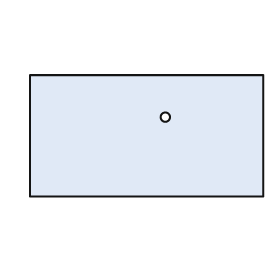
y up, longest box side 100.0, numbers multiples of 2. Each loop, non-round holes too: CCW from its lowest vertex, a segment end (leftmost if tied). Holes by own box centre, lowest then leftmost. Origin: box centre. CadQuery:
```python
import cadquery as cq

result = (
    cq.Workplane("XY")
    .moveTo(-50.0, -26.0)
    .lineTo(50.0, -26.0)
    .lineTo(50.0, 26.0)
    .lineTo(-50.0, 26.0)
    .close()
    .moveTo(8.0, 8.0)
    .circle(2.0)
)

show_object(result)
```